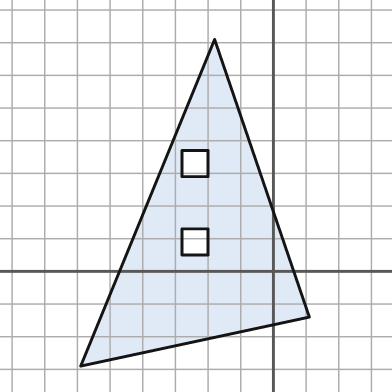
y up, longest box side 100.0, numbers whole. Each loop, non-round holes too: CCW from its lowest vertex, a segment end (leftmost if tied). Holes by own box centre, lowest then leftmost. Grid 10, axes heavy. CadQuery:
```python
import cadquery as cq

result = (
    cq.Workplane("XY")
    .moveTo(-59.0, -29.0)
    .lineTo(11.0, -14.0)
    .lineTo(-18.0, 71.0)
    .close()
    .moveTo(-28.0, 5.0)
    .lineTo(-20.0, 5.0)
    .lineTo(-20.0, 13.0)
    .lineTo(-28.0, 13.0)
    .close()
    .moveTo(-28.0, 29.0)
    .lineTo(-20.0, 29.0)
    .lineTo(-20.0, 37.0)
    .lineTo(-28.0, 37.0)
    .close()
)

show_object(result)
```